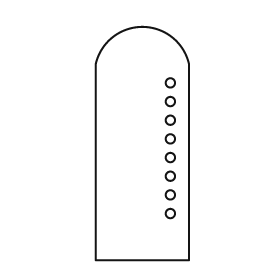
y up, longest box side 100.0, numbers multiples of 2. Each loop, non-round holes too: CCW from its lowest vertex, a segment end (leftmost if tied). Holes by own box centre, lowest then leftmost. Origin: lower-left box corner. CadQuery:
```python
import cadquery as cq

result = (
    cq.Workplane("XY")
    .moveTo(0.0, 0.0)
    .lineTo(40.0, 0.0)
    .lineTo(40.0, 84.0)
    .threePointArc((20.0, 100.0), (0.0, 84.0))
    .close()
    .moveTo(32.0, 20.0)
    .circle(2.0)
    .moveTo(32.0, 28.0)
    .circle(2.0)
    .moveTo(32.0, 36.0)
    .circle(2.0)
    .moveTo(32.0, 44.0)
    .circle(2.0)
    .moveTo(32.0, 52.0)
    .circle(2.0)
    .moveTo(32.0, 60.0)
    .circle(2.0)
    .moveTo(32.0, 68.0)
    .circle(2.0)
    .moveTo(32.0, 76.0)
    .circle(2.0)
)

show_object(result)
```